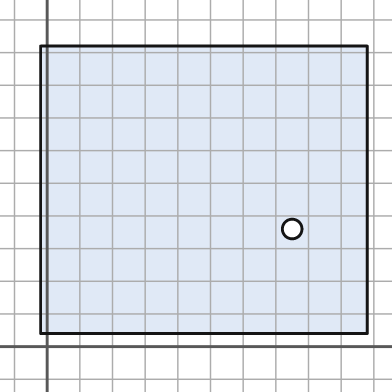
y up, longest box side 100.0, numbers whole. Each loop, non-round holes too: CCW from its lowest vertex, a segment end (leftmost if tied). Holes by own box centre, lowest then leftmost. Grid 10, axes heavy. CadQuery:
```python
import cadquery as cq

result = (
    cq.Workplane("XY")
    .moveTo(-2.0, 4.0)
    .lineTo(98.0, 4.0)
    .lineTo(98.0, 92.0)
    .lineTo(-2.0, 92.0)
    .close()
    .moveTo(75.0, 36.0)
    .circle(3.0)
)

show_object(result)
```